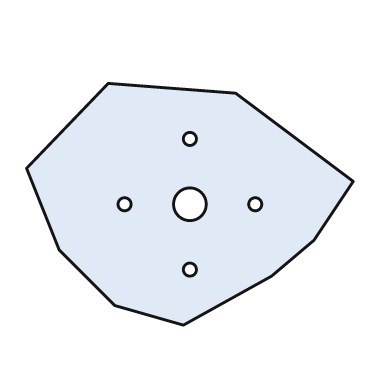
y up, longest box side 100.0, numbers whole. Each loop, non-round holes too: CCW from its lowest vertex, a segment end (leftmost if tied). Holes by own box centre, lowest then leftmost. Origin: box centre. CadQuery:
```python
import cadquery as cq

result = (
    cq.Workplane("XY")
    .moveTo(-2.0, -37.0)
    .lineTo(25.0, -22.0)
    .lineTo(38.0, -11.0)
    .lineTo(50.0, 7.0)
    .lineTo(14.0, 34.0)
    .lineTo(-25.0, 37.0)
    .lineTo(-50.0, 11.0)
    .lineTo(-40.0, -14.0)
    .lineTo(-23.0, -31.0)
    .close()
    .moveTo(0.0, -20.0)
    .circle(2.0)
    .moveTo(-20.0, 0.0)
    .circle(2.0)
    .moveTo(0.0, 0.0)
    .circle(5.0)
    .moveTo(20.0, 0.0)
    .circle(2.0)
    .moveTo(0.0, 20.0)
    .circle(2.0)
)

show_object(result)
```